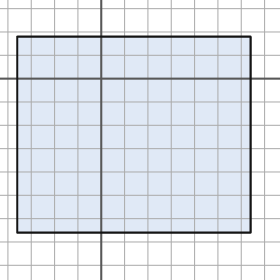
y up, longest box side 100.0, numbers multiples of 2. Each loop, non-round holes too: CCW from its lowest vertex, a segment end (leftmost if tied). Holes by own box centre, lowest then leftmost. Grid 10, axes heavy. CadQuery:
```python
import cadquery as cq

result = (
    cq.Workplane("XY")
    .moveTo(-36.0, -66.0)
    .lineTo(64.0, -66.0)
    .lineTo(64.0, 18.0)
    .lineTo(-36.0, 18.0)
    .close()
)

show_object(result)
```